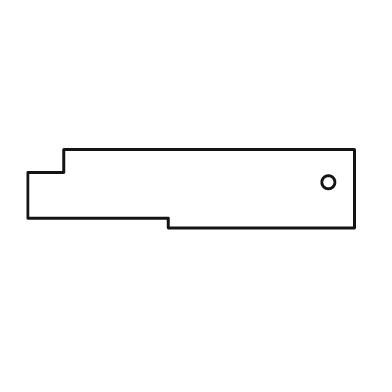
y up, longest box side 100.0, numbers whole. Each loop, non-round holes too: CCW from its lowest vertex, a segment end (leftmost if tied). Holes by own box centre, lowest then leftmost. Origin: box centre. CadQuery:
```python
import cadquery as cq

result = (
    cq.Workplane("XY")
    .moveTo(-7.0, -12.0)
    .lineTo(50.0, -12.0)
    .lineTo(50.0, 12.0)
    .lineTo(-39.0, 12.0)
    .lineTo(-39.0, 5.0)
    .lineTo(-50.0, 5.0)
    .lineTo(-50.0, -9.0)
    .lineTo(-7.0, -9.0)
    .close()
    .moveTo(42.0, 2.0)
    .circle(2.0)
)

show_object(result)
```